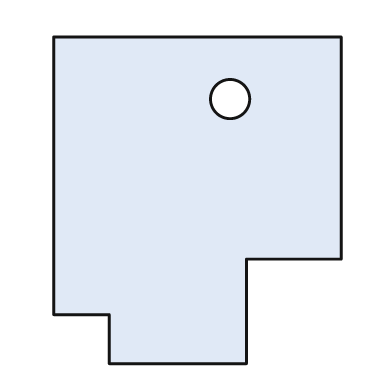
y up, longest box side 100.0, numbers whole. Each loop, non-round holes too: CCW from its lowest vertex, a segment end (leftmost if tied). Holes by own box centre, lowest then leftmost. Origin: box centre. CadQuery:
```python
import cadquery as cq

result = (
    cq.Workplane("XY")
    .moveTo(-27.0, -50.0)
    .lineTo(15.0, -50.0)
    .lineTo(15.0, -18.0)
    .lineTo(44.0, -18.0)
    .lineTo(44.0, 50.0)
    .lineTo(-44.0, 50.0)
    .lineTo(-44.0, -35.0)
    .lineTo(-27.0, -35.0)
    .close()
    .moveTo(10.0, 31.0)
    .circle(6.0)
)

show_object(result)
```